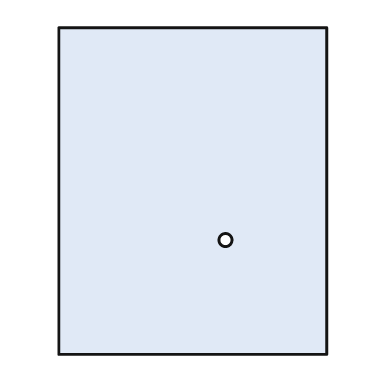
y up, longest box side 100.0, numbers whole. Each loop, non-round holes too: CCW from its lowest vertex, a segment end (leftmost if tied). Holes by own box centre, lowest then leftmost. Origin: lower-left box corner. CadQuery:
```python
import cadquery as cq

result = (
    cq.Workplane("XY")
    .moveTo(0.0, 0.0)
    .lineTo(82.0, 0.0)
    .lineTo(82.0, 100.0)
    .lineTo(0.0, 100.0)
    .close()
    .moveTo(51.0, 35.0)
    .circle(2.0)
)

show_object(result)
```